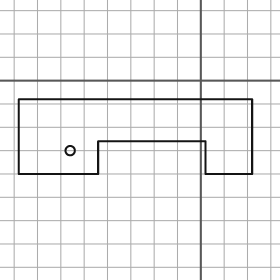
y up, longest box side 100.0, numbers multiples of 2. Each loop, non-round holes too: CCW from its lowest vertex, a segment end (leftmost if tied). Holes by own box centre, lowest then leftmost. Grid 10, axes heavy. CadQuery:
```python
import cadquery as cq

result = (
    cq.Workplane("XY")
    .moveTo(-78.0, -40.0)
    .lineTo(-44.0, -40.0)
    .lineTo(-44.0, -26.0)
    .lineTo(2.0, -26.0)
    .lineTo(2.0, -40.0)
    .lineTo(22.0, -40.0)
    .lineTo(22.0, -8.0)
    .lineTo(-78.0, -8.0)
    .close()
    .moveTo(-56.0, -30.0)
    .circle(2.0)
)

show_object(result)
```